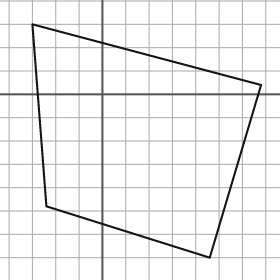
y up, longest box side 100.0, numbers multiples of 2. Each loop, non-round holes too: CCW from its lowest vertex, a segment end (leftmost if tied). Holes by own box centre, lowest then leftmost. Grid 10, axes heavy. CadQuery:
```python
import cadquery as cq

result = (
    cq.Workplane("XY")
    .moveTo(46.0, -70.0)
    .lineTo(68.0, 4.0)
    .lineTo(-30.0, 30.0)
    .lineTo(-24.0, -48.0)
    .close()
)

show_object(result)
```